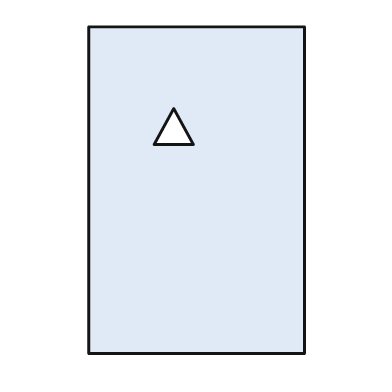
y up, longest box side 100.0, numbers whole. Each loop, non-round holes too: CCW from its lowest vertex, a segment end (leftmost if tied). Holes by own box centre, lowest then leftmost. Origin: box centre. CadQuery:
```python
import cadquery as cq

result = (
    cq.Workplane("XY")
    .moveTo(-33.0, -50.0)
    .lineTo(33.0, -50.0)
    .lineTo(33.0, 50.0)
    .lineTo(-33.0, 50.0)
    .close()
    .moveTo(-13.0, 14.0)
    .lineTo(-1.0, 14.0)
    .lineTo(-7.0, 25.0)
    .close()
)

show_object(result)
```